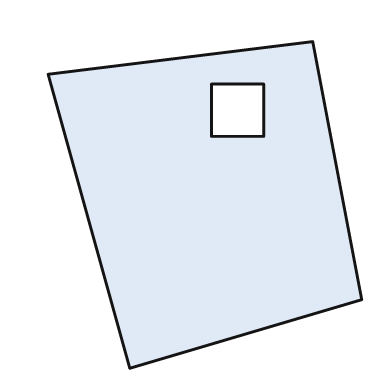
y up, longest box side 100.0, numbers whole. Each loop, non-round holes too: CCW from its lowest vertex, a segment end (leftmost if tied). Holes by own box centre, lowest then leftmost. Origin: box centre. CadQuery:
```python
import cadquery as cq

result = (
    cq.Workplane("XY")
    .moveTo(-23.0, -50.0)
    .lineTo(48.0, -29.0)
    .lineTo(33.0, 50.0)
    .lineTo(-48.0, 40.0)
    .close()
    .moveTo(2.0, 21.0)
    .lineTo(18.0, 21.0)
    .lineTo(18.0, 37.0)
    .lineTo(2.0, 37.0)
    .close()
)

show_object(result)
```